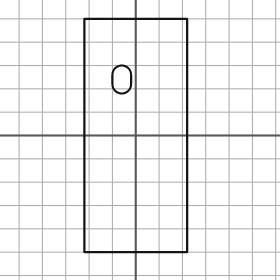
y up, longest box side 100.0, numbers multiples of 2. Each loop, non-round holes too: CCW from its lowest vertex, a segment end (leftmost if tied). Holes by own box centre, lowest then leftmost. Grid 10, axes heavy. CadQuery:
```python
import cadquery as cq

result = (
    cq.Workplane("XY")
    .moveTo(-22.0, -50.0)
    .lineTo(22.0, -50.0)
    .lineTo(22.0, 50.0)
    .lineTo(-22.0, 50.0)
    .close()
    .moveTo(-10.0, 22.0)
    .threePointArc((-6.0, 18.0), (-2.0, 22.0))
    .lineTo(-2.0, 26.0)
    .threePointArc((-6.0, 30.0), (-10.0, 26.0))
    .close()
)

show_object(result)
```